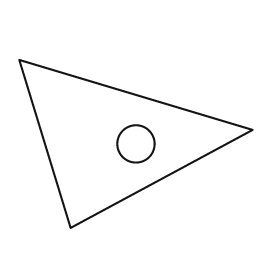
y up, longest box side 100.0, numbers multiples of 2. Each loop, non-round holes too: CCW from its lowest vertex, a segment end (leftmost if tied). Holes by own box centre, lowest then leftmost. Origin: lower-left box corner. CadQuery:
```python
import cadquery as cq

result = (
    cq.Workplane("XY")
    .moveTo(22.0, 0.0)
    .lineTo(100.0, 42.0)
    .lineTo(0.0, 72.0)
    .close()
    .moveTo(50.0, 36.0)
    .circle(8.0)
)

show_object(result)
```